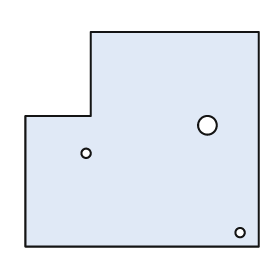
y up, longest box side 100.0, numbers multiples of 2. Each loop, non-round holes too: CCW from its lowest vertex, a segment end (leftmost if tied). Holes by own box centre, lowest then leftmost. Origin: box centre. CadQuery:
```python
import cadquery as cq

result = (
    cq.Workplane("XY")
    .moveTo(-50.0, -46.0)
    .lineTo(50.0, -46.0)
    .lineTo(50.0, 46.0)
    .lineTo(-22.0, 46.0)
    .lineTo(-22.0, 10.0)
    .lineTo(-50.0, 10.0)
    .close()
    .moveTo(42.0, -40.0)
    .circle(2.0)
    .moveTo(-24.0, -6.0)
    .circle(2.0)
    .moveTo(28.0, 6.0)
    .circle(4.0)
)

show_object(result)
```